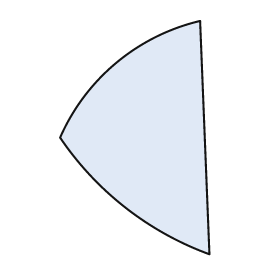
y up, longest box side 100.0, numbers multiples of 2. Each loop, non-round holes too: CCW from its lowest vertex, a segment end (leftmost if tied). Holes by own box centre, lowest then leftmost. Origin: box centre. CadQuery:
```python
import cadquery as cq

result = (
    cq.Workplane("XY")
    .moveTo(32.0, -50.0)
    .lineTo(28.0, 50.0)
    .threePointArc((-8.0, 32.0), (-32.0, 0.0))
    .threePointArc((-4.0, -30.0), (32.0, -50.0))
    .close()
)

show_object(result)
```